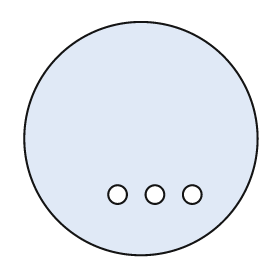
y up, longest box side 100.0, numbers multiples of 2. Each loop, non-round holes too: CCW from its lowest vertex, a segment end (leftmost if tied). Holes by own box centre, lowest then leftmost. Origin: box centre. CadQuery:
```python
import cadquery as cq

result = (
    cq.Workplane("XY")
    .moveTo(0.0, 0.0)
    .circle(50.0)
    .moveTo(-10.0, -24.0)
    .circle(4.0)
    .moveTo(6.0, -24.0)
    .circle(4.0)
    .moveTo(22.0, -24.0)
    .circle(4.0)
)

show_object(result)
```